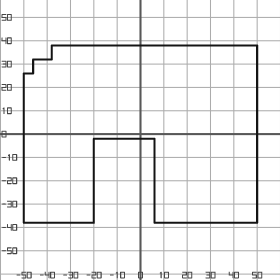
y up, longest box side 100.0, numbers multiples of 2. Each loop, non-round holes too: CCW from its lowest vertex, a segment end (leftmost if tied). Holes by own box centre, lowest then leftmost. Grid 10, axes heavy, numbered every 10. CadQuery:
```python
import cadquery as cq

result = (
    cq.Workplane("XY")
    .moveTo(-50.0, -38.0)
    .lineTo(-20.0, -38.0)
    .lineTo(-20.0, -2.0)
    .lineTo(6.0, -2.0)
    .lineTo(6.0, -38.0)
    .lineTo(50.0, -38.0)
    .lineTo(50.0, 38.0)
    .lineTo(-38.0, 38.0)
    .lineTo(-38.0, 32.0)
    .lineTo(-46.0, 32.0)
    .lineTo(-46.0, 26.0)
    .lineTo(-50.0, 26.0)
    .close()
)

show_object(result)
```